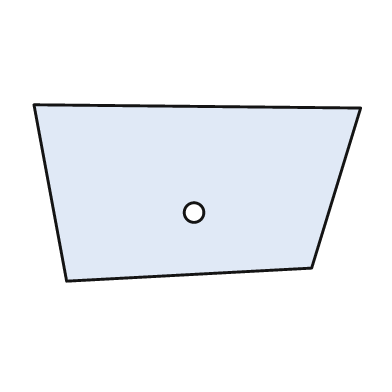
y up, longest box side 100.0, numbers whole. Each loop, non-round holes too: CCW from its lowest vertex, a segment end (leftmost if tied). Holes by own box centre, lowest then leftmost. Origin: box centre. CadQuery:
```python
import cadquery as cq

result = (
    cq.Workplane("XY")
    .moveTo(-40.0, -27.0)
    .lineTo(35.0, -23.0)
    .lineTo(50.0, 26.0)
    .lineTo(-50.0, 27.0)
    .close()
    .moveTo(-1.0, -6.0)
    .circle(3.0)
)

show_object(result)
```